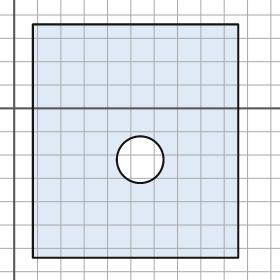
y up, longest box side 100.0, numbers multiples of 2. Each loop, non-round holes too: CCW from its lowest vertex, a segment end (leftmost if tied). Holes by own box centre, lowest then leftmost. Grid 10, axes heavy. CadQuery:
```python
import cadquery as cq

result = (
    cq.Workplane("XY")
    .moveTo(8.0, -64.0)
    .lineTo(96.0, -64.0)
    .lineTo(96.0, 36.0)
    .lineTo(8.0, 36.0)
    .close()
    .moveTo(54.0, -22.0)
    .circle(10.0)
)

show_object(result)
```